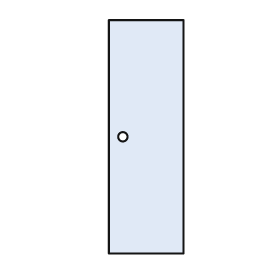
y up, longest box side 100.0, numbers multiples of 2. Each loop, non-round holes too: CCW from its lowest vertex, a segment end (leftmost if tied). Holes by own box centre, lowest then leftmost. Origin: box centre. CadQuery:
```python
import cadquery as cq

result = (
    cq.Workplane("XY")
    .moveTo(-16.0, -50.0)
    .lineTo(16.0, -50.0)
    .lineTo(16.0, 50.0)
    .lineTo(-16.0, 50.0)
    .close()
    .moveTo(-10.0, 0.0)
    .circle(2.0)
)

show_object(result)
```